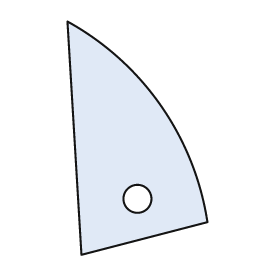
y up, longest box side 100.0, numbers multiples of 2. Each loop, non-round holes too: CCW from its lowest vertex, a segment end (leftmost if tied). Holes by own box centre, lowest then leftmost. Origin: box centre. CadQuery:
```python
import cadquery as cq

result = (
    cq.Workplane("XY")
    .moveTo(-24.0, -50.0)
    .lineTo(30.0, -36.0)
    .threePointArc((10.0, 14.0), (-30.0, 50.0))
    .close()
    .moveTo(0.0, -26.0)
    .circle(6.0)
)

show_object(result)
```